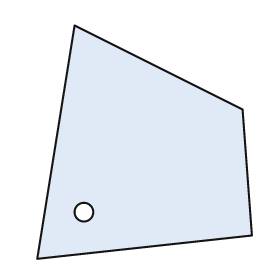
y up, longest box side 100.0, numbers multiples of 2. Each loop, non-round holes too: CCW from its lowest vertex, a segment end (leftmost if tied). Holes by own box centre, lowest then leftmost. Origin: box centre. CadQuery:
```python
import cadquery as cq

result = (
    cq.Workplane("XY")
    .moveTo(-46.0, -50.0)
    .lineTo(46.0, -40.0)
    .lineTo(42.0, 14.0)
    .lineTo(-30.0, 50.0)
    .close()
    .moveTo(-26.0, -30.0)
    .circle(4.0)
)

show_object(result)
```